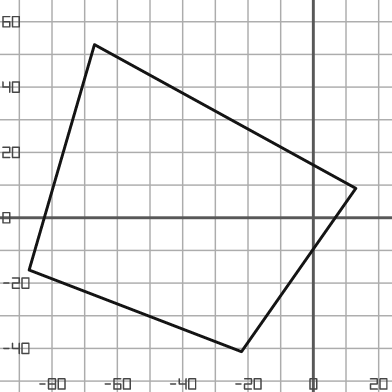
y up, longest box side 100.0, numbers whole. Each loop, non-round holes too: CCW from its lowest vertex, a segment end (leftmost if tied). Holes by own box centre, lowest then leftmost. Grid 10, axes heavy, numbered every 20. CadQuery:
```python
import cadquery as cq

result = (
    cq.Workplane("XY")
    .moveTo(-22.0, -41.0)
    .lineTo(13.0, 9.0)
    .lineTo(-67.0, 53.0)
    .lineTo(-87.0, -16.0)
    .close()
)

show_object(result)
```